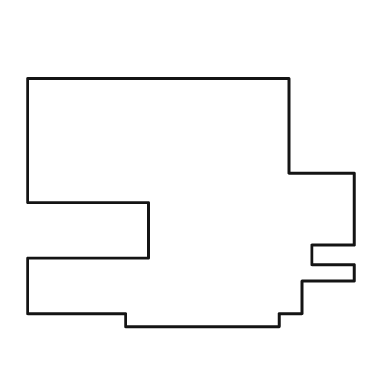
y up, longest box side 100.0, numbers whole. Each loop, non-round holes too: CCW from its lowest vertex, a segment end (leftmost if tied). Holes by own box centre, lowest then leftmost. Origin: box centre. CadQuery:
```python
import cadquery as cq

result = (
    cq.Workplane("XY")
    .moveTo(-20.0, -38.0)
    .lineTo(27.0, -38.0)
    .lineTo(27.0, -34.0)
    .lineTo(34.0, -34.0)
    .lineTo(34.0, -24.0)
    .lineTo(50.0, -24.0)
    .lineTo(50.0, -19.0)
    .lineTo(37.0, -19.0)
    .lineTo(37.0, -13.0)
    .lineTo(50.0, -13.0)
    .lineTo(50.0, 9.0)
    .lineTo(30.0, 9.0)
    .lineTo(30.0, 38.0)
    .lineTo(-50.0, 38.0)
    .lineTo(-50.0, 0.0)
    .lineTo(-13.0, 0.0)
    .lineTo(-13.0, -17.0)
    .lineTo(-50.0, -17.0)
    .lineTo(-50.0, -34.0)
    .lineTo(-20.0, -34.0)
    .close()
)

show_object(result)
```